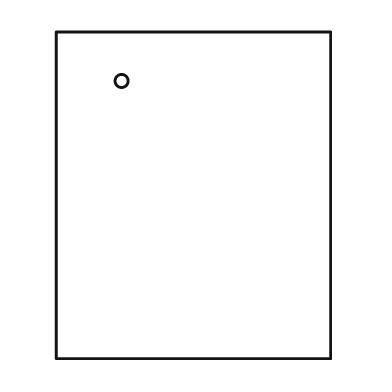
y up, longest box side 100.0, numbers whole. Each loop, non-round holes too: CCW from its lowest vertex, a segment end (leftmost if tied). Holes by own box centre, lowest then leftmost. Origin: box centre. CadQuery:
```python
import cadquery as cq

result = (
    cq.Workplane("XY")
    .moveTo(-42.0, -50.0)
    .lineTo(42.0, -50.0)
    .lineTo(42.0, 50.0)
    .lineTo(-42.0, 50.0)
    .close()
    .moveTo(-22.0, 35.0)
    .circle(2.0)
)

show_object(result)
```